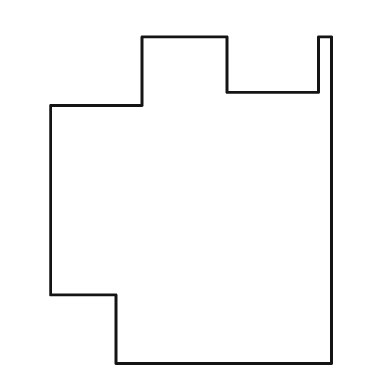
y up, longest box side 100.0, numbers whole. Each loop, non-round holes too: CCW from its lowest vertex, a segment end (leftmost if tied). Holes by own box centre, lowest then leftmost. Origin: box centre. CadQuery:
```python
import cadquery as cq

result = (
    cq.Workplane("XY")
    .moveTo(-23.0, -50.0)
    .lineTo(43.0, -50.0)
    .lineTo(43.0, 50.0)
    .lineTo(39.0, 50.0)
    .lineTo(39.0, 33.0)
    .lineTo(11.0, 33.0)
    .lineTo(11.0, 50.0)
    .lineTo(-15.0, 50.0)
    .lineTo(-15.0, 29.0)
    .lineTo(-43.0, 29.0)
    .lineTo(-43.0, -29.0)
    .lineTo(-23.0, -29.0)
    .close()
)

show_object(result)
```